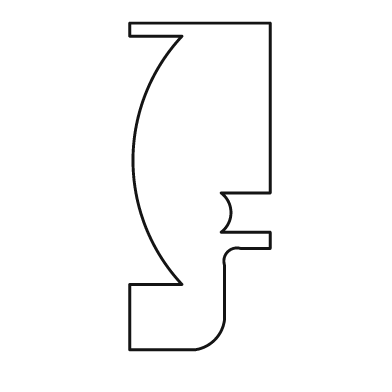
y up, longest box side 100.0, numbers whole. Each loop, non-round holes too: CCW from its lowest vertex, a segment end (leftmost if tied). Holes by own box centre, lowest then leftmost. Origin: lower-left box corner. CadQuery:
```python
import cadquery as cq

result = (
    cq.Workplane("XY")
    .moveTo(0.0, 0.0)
    .lineTo(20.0, 0.0)
    .threePointArc((26.0, 3.0), (29.0, 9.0))
    .lineTo(29.0, 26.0)
    .threePointArc((30.0, 30.0), (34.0, 31.0))
    .lineTo(43.0, 31.0)
    .lineTo(43.0, 36.0)
    .lineTo(28.0, 36.0)
    .threePointArc((31.0, 42.0), (28.0, 48.0))
    .lineTo(43.0, 48.0)
    .lineTo(43.0, 100.0)
    .lineTo(0.0, 100.0)
    .lineTo(0.0, 96.0)
    .lineTo(16.0, 96.0)
    .threePointArc((1.0, 58.0), (16.0, 20.0))
    .lineTo(0.0, 20.0)
    .close()
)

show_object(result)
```